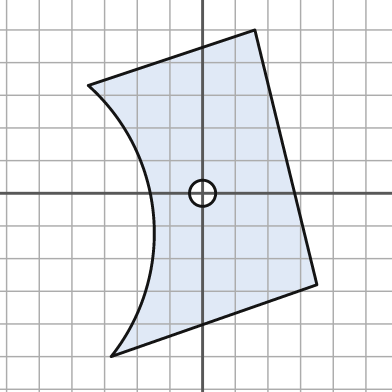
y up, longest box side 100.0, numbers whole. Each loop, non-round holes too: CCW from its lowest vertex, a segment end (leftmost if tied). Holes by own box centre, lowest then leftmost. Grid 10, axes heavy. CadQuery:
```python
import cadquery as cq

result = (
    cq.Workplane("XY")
    .moveTo(-28.0, -50.0)
    .lineTo(35.0, -28.0)
    .lineTo(16.0, 50.0)
    .lineTo(-35.0, 33.0)
    .threePointArc((-15.0, -7.0), (-28.0, -50.0))
    .close()
    .moveTo(0.0, 0.0)
    .circle(4.0)
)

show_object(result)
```